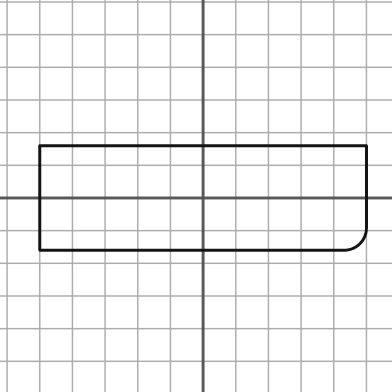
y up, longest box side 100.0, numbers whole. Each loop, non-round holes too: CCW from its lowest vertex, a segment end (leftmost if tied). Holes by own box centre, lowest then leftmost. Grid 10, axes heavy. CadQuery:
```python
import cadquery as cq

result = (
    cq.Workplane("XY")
    .moveTo(-50.0, -16.0)
    .lineTo(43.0, -16.0)
    .threePointArc((48.0, -14.0), (50.0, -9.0))
    .lineTo(50.0, 16.0)
    .lineTo(-50.0, 16.0)
    .close()
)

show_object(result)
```